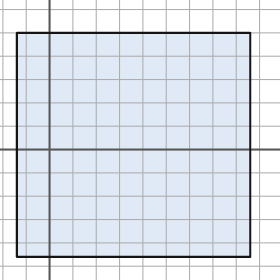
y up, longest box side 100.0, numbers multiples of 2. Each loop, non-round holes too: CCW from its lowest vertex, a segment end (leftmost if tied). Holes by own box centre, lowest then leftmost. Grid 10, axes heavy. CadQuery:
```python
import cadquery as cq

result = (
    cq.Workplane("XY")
    .moveTo(-14.0, -46.0)
    .lineTo(86.0, -46.0)
    .lineTo(86.0, 50.0)
    .lineTo(-14.0, 50.0)
    .close()
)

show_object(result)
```